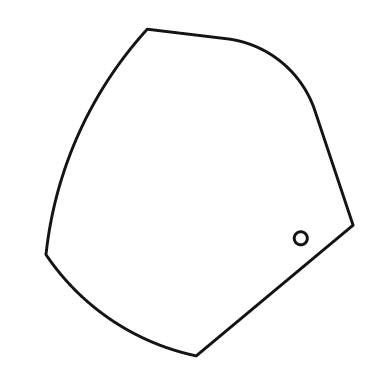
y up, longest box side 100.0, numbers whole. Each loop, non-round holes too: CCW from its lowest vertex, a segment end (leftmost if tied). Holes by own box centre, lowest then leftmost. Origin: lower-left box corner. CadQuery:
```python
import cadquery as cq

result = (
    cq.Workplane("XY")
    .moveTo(46.0, 0.0)
    .lineTo(94.0, 40.0)
    .lineTo(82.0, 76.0)
    .threePointArc((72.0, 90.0), (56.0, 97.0))
    .lineTo(31.0, 100.0)
    .threePointArc((10.0, 68.0), (0.0, 31.0))
    .threePointArc((20.0, 11.0), (46.0, 0.0))
    .close()
    .moveTo(78.0, 36.0)
    .circle(2.0)
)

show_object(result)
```